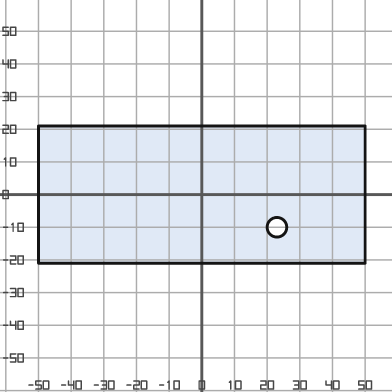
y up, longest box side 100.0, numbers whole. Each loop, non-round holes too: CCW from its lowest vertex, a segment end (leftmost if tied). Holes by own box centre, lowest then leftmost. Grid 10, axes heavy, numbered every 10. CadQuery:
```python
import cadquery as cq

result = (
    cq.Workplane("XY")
    .moveTo(-50.0, -21.0)
    .lineTo(50.0, -21.0)
    .lineTo(50.0, 21.0)
    .lineTo(-50.0, 21.0)
    .close()
    .moveTo(23.0, -10.0)
    .circle(3.0)
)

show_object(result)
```